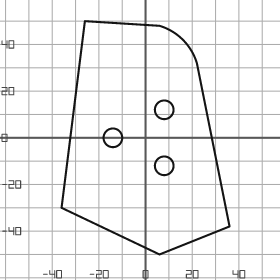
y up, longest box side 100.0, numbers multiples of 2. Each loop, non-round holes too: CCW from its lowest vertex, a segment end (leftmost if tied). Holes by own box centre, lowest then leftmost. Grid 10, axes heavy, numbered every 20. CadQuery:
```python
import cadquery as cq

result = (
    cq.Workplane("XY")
    .moveTo(6.0, -50.0)
    .lineTo(36.0, -38.0)
    .lineTo(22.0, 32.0)
    .threePointArc((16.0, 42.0), (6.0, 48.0))
    .lineTo(-26.0, 50.0)
    .lineTo(-36.0, -30.0)
    .close()
    .moveTo(8.0, -12.0)
    .circle(4.0)
    .moveTo(-14.0, 0.0)
    .circle(4.0)
    .moveTo(8.0, 12.0)
    .circle(4.0)
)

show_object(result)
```